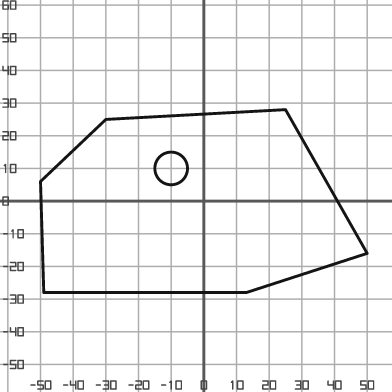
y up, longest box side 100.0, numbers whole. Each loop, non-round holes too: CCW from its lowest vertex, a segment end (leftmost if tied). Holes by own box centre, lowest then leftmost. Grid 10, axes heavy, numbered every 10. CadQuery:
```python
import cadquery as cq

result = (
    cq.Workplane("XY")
    .moveTo(-49.0, -28.0)
    .lineTo(13.0, -28.0)
    .lineTo(50.0, -16.0)
    .lineTo(25.0, 28.0)
    .lineTo(-30.0, 25.0)
    .lineTo(-50.0, 6.0)
    .close()
    .moveTo(-10.0, 10.0)
    .circle(5.0)
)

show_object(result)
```